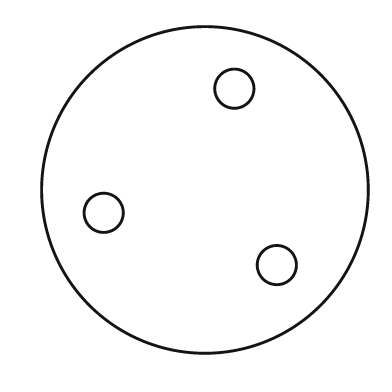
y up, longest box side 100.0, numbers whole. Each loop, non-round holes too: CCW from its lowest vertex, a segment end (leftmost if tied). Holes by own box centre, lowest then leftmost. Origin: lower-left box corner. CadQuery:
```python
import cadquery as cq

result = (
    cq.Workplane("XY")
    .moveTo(50.0, 50.0)
    .circle(50.0)
    .moveTo(72.0, 27.0)
    .circle(6.0)
    .moveTo(19.0, 43.0)
    .circle(6.0)
    .moveTo(59.0, 81.0)
    .circle(6.0)
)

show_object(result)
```